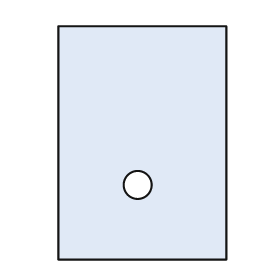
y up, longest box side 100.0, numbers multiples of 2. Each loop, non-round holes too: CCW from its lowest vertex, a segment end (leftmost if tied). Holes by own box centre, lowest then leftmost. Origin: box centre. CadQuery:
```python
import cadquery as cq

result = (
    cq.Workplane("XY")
    .moveTo(-36.0, -50.0)
    .lineTo(36.0, -50.0)
    .lineTo(36.0, 50.0)
    .lineTo(-36.0, 50.0)
    .close()
    .moveTo(-2.0, -18.0)
    .circle(6.0)
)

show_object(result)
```